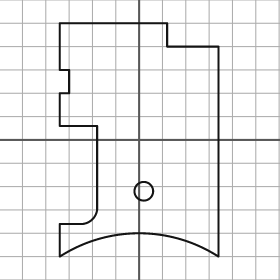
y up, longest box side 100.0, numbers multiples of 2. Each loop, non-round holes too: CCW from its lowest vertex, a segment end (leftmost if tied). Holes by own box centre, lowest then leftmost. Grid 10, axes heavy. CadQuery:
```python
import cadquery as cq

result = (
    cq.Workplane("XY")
    .moveTo(-34.0, -50.0)
    .threePointArc((0.0, -40.0), (34.0, -50.0))
    .lineTo(34.0, 40.0)
    .lineTo(12.0, 40.0)
    .lineTo(12.0, 50.0)
    .lineTo(-34.0, 50.0)
    .lineTo(-34.0, 30.0)
    .lineTo(-30.0, 30.0)
    .lineTo(-30.0, 20.0)
    .lineTo(-34.0, 20.0)
    .lineTo(-34.0, 6.0)
    .lineTo(-18.0, 6.0)
    .lineTo(-18.0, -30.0)
    .threePointArc((-20.0, -34.0), (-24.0, -36.0))
    .lineTo(-34.0, -36.0)
    .close()
    .moveTo(2.0, -22.0)
    .circle(4.0)
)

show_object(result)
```